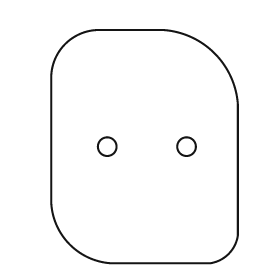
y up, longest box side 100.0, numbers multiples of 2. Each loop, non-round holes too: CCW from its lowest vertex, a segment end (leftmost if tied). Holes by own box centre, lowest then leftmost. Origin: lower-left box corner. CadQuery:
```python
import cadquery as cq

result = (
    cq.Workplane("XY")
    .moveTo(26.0, 0.0)
    .lineTo(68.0, 0.0)
    .threePointArc((76.0, 4.0), (80.0, 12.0))
    .lineTo(80.0, 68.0)
    .threePointArc((70.0, 90.0), (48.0, 100.0))
    .lineTo(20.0, 100.0)
    .threePointArc((6.0, 94.0), (0.0, 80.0))
    .lineTo(0.0, 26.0)
    .threePointArc((8.0, 8.0), (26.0, 0.0))
    .close()
    .moveTo(24.0, 50.0)
    .circle(4.0)
    .moveTo(58.0, 50.0)
    .circle(4.0)
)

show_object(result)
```